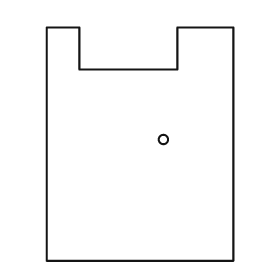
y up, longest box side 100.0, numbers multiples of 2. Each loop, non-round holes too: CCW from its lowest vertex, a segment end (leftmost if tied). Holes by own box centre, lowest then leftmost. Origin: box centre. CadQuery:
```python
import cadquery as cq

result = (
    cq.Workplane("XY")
    .moveTo(-40.0, -50.0)
    .lineTo(40.0, -50.0)
    .lineTo(40.0, 50.0)
    .lineTo(16.0, 50.0)
    .lineTo(16.0, 32.0)
    .lineTo(-26.0, 32.0)
    .lineTo(-26.0, 50.0)
    .lineTo(-40.0, 50.0)
    .close()
    .moveTo(10.0, 2.0)
    .circle(2.0)
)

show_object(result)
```